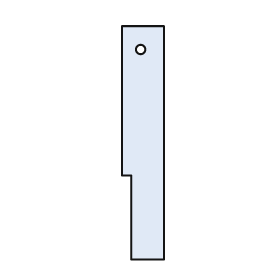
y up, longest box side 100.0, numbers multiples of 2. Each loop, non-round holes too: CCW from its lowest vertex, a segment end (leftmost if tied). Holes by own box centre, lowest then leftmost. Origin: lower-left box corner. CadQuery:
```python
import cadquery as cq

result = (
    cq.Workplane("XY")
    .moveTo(4.0, 0.0)
    .lineTo(18.0, 0.0)
    .lineTo(18.0, 100.0)
    .lineTo(0.0, 100.0)
    .lineTo(0.0, 36.0)
    .lineTo(4.0, 36.0)
    .close()
    .moveTo(8.0, 90.0)
    .circle(2.0)
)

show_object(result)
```